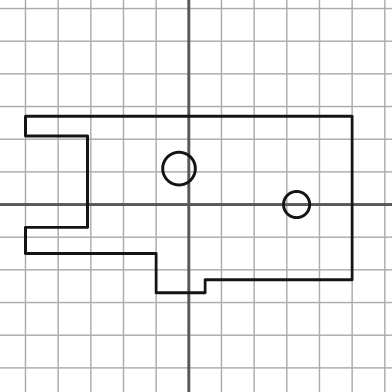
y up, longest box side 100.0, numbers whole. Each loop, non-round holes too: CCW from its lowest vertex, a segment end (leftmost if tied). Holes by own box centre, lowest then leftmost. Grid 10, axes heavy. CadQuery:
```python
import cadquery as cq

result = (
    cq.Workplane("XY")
    .moveTo(-10.0, -27.0)
    .lineTo(5.0, -27.0)
    .lineTo(5.0, -23.0)
    .lineTo(50.0, -23.0)
    .lineTo(50.0, 27.0)
    .lineTo(-50.0, 27.0)
    .lineTo(-50.0, 21.0)
    .lineTo(-31.0, 21.0)
    .lineTo(-31.0, -7.0)
    .lineTo(-50.0, -7.0)
    .lineTo(-50.0, -15.0)
    .lineTo(-10.0, -15.0)
    .close()
    .moveTo(33.0, 0.0)
    .circle(4.0)
    .moveTo(-3.0, 11.0)
    .circle(5.0)
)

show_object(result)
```